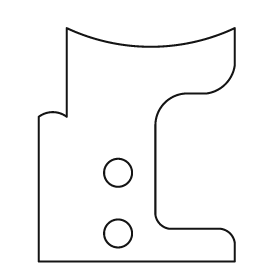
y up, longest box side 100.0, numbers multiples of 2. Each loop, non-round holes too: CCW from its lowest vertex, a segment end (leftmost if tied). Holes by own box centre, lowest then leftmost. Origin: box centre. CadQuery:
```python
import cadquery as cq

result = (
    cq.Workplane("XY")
    .moveTo(-42.0, -50.0)
    .lineTo(42.0, -50.0)
    .lineTo(42.0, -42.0)
    .threePointArc((40.0, -38.0), (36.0, -36.0))
    .lineTo(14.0, -36.0)
    .threePointArc((10.0, -34.0), (8.0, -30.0))
    .lineTo(8.0, 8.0)
    .threePointArc((12.0, 18.0), (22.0, 22.0))
    .lineTo(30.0, 22.0)
    .threePointArc((38.0, 26.0), (42.0, 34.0))
    .lineTo(42.0, 50.0)
    .threePointArc((6.0, 42.0), (-30.0, 50.0))
    .lineTo(-30.0, 12.0)
    .threePointArc((-36.0, 14.0), (-42.0, 12.0))
    .close()
    .moveTo(-8.0, -38.0)
    .circle(6.0)
    .moveTo(-8.0, -12.0)
    .circle(6.0)
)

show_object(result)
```